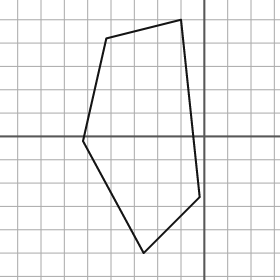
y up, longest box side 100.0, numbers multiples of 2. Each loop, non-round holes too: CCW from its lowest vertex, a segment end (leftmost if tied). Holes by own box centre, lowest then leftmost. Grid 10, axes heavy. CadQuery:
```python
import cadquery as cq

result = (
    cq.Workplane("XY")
    .moveTo(-26.0, -50.0)
    .lineTo(-2.0, -26.0)
    .lineTo(-10.0, 50.0)
    .lineTo(-42.0, 42.0)
    .lineTo(-52.0, -2.0)
    .close()
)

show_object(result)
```